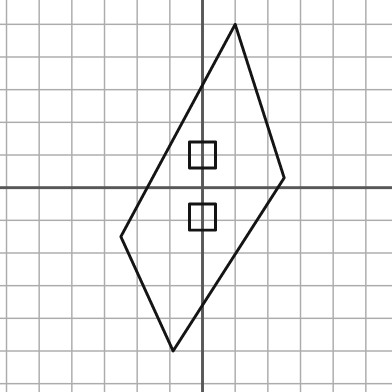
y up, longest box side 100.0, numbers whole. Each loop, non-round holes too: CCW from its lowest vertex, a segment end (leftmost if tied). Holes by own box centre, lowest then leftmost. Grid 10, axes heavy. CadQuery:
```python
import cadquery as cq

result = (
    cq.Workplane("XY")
    .moveTo(-9.0, -50.0)
    .lineTo(25.0, 3.0)
    .lineTo(10.0, 50.0)
    .lineTo(-25.0, -15.0)
    .close()
    .moveTo(-4.0, -13.0)
    .lineTo(4.0, -13.0)
    .lineTo(4.0, -5.0)
    .lineTo(-4.0, -5.0)
    .close()
    .moveTo(-4.0, 6.0)
    .lineTo(4.0, 6.0)
    .lineTo(4.0, 14.0)
    .lineTo(-4.0, 14.0)
    .close()
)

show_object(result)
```